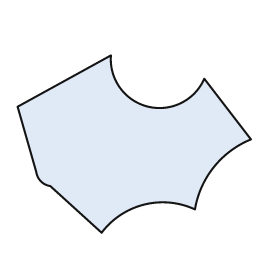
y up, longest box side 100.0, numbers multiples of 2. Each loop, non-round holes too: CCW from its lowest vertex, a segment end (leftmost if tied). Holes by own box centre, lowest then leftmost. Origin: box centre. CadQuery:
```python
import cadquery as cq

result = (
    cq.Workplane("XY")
    .moveTo(-14.0, -38.0)
    .threePointArc((4.0, -26.0), (26.0, -28.0))
    .threePointArc((34.0, -10.0), (50.0, 2.0))
    .lineTo(30.0, 28.0)
    .threePointArc((6.0, 16.0), (-10.0, 38.0))
    .lineTo(-50.0, 16.0)
    .lineTo(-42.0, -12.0)
    .threePointArc((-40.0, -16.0), (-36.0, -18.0))
    .close()
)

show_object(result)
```